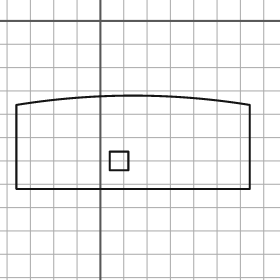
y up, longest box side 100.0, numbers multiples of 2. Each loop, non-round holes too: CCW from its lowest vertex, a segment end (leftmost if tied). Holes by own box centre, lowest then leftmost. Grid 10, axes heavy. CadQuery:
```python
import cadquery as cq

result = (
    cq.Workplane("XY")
    .moveTo(-36.0, -72.0)
    .lineTo(64.0, -72.0)
    .lineTo(64.0, -36.0)
    .threePointArc((14.0, -32.0), (-36.0, -36.0))
    .close()
    .moveTo(4.0, -64.0)
    .lineTo(12.0, -64.0)
    .lineTo(12.0, -56.0)
    .lineTo(4.0, -56.0)
    .close()
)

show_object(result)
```